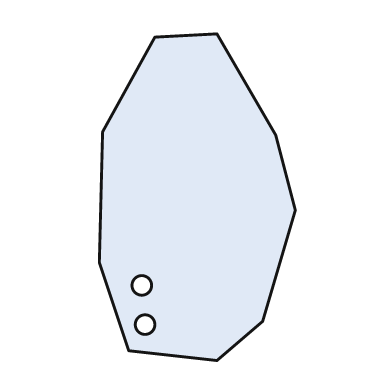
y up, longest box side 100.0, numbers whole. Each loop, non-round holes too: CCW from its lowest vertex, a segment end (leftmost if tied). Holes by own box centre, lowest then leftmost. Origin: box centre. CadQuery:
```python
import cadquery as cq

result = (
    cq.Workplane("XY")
    .moveTo(6.0, -50.0)
    .lineTo(20.0, -38.0)
    .lineTo(30.0, -4.0)
    .lineTo(24.0, 19.0)
    .lineTo(6.0, 50.0)
    .lineTo(-13.0, 49.0)
    .lineTo(-29.0, 20.0)
    .lineTo(-30.0, -20.0)
    .lineTo(-21.0, -47.0)
    .close()
    .moveTo(-16.0, -39.0)
    .circle(3.0)
    .moveTo(-17.0, -27.0)
    .circle(3.0)
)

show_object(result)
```